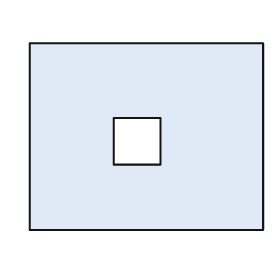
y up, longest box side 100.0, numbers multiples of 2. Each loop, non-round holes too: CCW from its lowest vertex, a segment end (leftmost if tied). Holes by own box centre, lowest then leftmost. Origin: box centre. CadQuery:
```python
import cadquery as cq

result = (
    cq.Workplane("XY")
    .moveTo(-50.0, -40.0)
    .lineTo(50.0, -40.0)
    .lineTo(50.0, 40.0)
    .lineTo(-50.0, 40.0)
    .close()
    .moveTo(-14.0, -12.0)
    .lineTo(6.0, -12.0)
    .lineTo(6.0, 8.0)
    .lineTo(-14.0, 8.0)
    .close()
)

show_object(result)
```